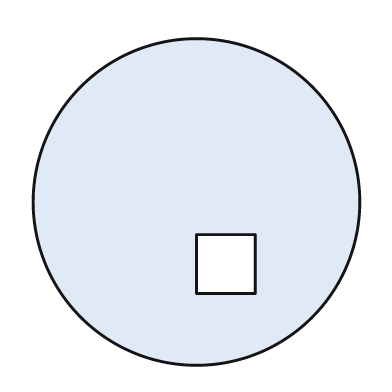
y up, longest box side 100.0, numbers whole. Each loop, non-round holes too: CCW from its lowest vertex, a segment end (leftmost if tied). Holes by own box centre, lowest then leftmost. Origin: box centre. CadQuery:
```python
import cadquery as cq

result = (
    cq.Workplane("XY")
    .moveTo(0.0, 0.0)
    .circle(50.0)
    .moveTo(0.0, -28.0)
    .lineTo(18.0, -28.0)
    .lineTo(18.0, -10.0)
    .lineTo(0.0, -10.0)
    .close()
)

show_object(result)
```